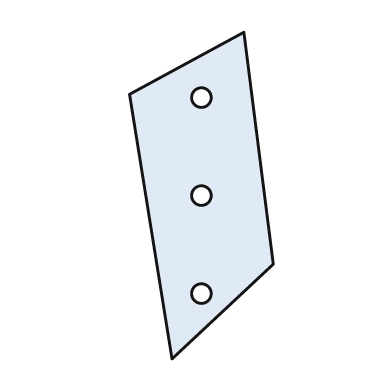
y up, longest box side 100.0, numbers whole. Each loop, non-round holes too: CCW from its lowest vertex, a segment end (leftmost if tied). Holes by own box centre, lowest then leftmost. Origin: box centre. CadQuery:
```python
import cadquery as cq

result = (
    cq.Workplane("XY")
    .moveTo(-9.0, -50.0)
    .lineTo(22.0, -21.0)
    .lineTo(13.0, 50.0)
    .lineTo(-22.0, 31.0)
    .close()
    .moveTo(0.0, -30.0)
    .circle(3.0)
    .moveTo(0.0, 0.0)
    .circle(3.0)
    .moveTo(0.0, 30.0)
    .circle(3.0)
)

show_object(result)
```